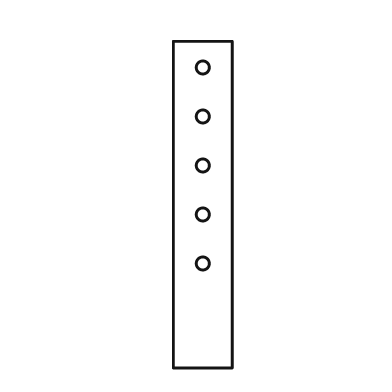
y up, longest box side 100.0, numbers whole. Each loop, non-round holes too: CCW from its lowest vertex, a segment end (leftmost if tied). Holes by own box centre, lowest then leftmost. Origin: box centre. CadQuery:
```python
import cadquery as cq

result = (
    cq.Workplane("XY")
    .moveTo(-9.0, -50.0)
    .lineTo(9.0, -50.0)
    .lineTo(9.0, 50.0)
    .lineTo(-9.0, 50.0)
    .close()
    .moveTo(0.0, -18.0)
    .circle(2.0)
    .moveTo(0.0, -3.0)
    .circle(2.0)
    .moveTo(0.0, 12.0)
    .circle(2.0)
    .moveTo(0.0, 27.0)
    .circle(2.0)
    .moveTo(0.0, 42.0)
    .circle(2.0)
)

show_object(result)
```